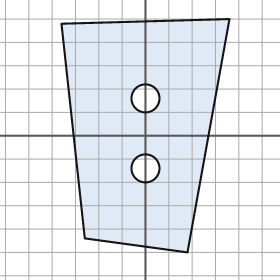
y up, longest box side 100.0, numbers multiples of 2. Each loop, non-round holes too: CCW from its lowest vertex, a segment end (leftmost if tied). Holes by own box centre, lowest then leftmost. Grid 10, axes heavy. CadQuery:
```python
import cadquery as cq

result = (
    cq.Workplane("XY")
    .moveTo(18.0, -50.0)
    .lineTo(36.0, 50.0)
    .lineTo(-36.0, 48.0)
    .lineTo(-26.0, -44.0)
    .close()
    .moveTo(0.0, -14.0)
    .circle(6.0)
    .moveTo(0.0, 16.0)
    .circle(6.0)
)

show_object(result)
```